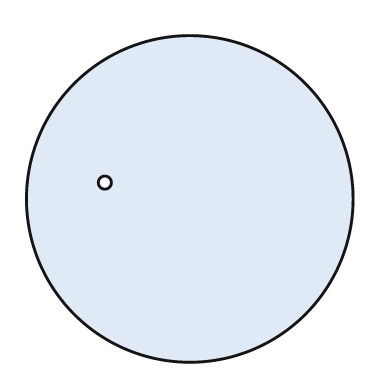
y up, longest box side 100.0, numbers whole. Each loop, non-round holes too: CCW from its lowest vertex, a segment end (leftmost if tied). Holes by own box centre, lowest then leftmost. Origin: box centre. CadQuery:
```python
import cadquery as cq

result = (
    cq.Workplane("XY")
    .moveTo(0.0, 0.0)
    .circle(50.0)
    .moveTo(-26.0, 5.0)
    .circle(2.0)
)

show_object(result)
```